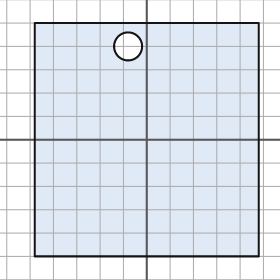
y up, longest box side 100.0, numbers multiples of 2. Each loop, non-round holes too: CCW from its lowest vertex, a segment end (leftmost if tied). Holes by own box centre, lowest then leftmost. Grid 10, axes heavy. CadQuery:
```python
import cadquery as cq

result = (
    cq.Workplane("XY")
    .moveTo(-48.0, -50.0)
    .lineTo(48.0, -50.0)
    .lineTo(48.0, 50.0)
    .lineTo(-48.0, 50.0)
    .close()
    .moveTo(-8.0, 40.0)
    .circle(6.0)
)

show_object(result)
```